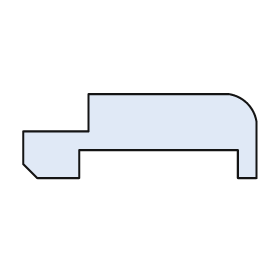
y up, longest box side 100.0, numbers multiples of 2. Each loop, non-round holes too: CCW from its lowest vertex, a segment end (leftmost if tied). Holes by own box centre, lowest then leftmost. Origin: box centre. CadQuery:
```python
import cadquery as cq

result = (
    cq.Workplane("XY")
    .moveTo(-44.0, -18.0)
    .lineTo(-26.0, -18.0)
    .lineTo(-26.0, -6.0)
    .lineTo(42.0, -6.0)
    .lineTo(42.0, -18.0)
    .lineTo(50.0, -18.0)
    .lineTo(50.0, 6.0)
    .threePointArc((46.0, 14.0), (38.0, 18.0))
    .lineTo(-22.0, 18.0)
    .lineTo(-22.0, 2.0)
    .lineTo(-50.0, 2.0)
    .lineTo(-50.0, -12.0)
    .close()
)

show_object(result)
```